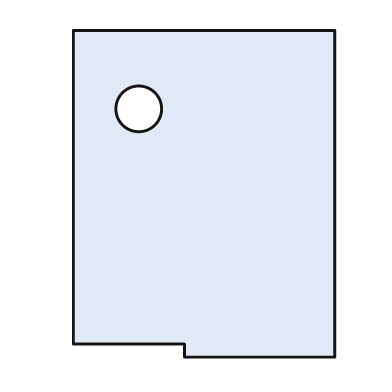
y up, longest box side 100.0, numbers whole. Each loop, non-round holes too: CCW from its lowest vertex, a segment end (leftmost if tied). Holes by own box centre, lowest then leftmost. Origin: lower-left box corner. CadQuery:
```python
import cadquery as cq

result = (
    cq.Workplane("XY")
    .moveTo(34.0, 0.0)
    .lineTo(80.0, 0.0)
    .lineTo(80.0, 100.0)
    .lineTo(0.0, 100.0)
    .lineTo(0.0, 4.0)
    .lineTo(34.0, 4.0)
    .close()
    .moveTo(20.0, 76.0)
    .circle(7.0)
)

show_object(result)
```